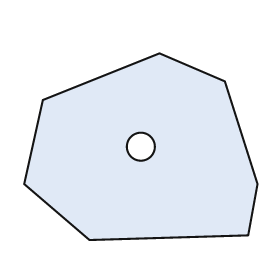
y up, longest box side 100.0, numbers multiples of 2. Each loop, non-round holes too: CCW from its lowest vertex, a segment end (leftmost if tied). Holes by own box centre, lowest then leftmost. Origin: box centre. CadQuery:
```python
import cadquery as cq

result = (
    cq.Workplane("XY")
    .moveTo(-22.0, -40.0)
    .lineTo(46.0, -38.0)
    .lineTo(50.0, -16.0)
    .lineTo(36.0, 28.0)
    .lineTo(8.0, 40.0)
    .lineTo(-42.0, 20.0)
    .lineTo(-50.0, -16.0)
    .close()
    .moveTo(0.0, 0.0)
    .circle(6.0)
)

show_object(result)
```